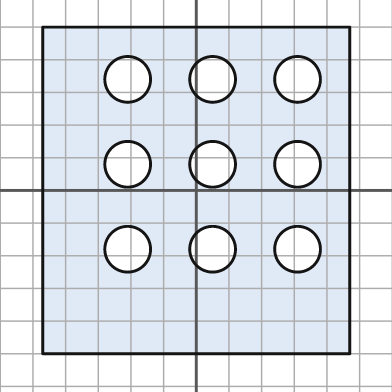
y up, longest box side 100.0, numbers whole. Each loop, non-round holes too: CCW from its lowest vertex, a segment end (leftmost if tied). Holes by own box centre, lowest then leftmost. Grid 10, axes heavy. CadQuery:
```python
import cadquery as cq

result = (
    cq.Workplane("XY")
    .moveTo(-47.0, -50.0)
    .lineTo(47.0, -50.0)
    .lineTo(47.0, 50.0)
    .lineTo(-47.0, 50.0)
    .close()
    .moveTo(-21.0, -18.0)
    .circle(7.0)
    .moveTo(5.0, -18.0)
    .circle(7.0)
    .moveTo(31.0, -18.0)
    .circle(7.0)
    .moveTo(-21.0, 8.0)
    .circle(7.0)
    .moveTo(5.0, 8.0)
    .circle(7.0)
    .moveTo(31.0, 8.0)
    .circle(7.0)
    .moveTo(-21.0, 34.0)
    .circle(7.0)
    .moveTo(5.0, 34.0)
    .circle(7.0)
    .moveTo(31.0, 34.0)
    .circle(7.0)
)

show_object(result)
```